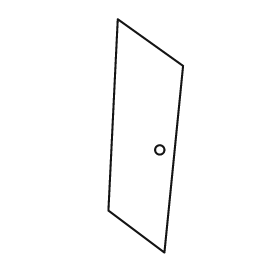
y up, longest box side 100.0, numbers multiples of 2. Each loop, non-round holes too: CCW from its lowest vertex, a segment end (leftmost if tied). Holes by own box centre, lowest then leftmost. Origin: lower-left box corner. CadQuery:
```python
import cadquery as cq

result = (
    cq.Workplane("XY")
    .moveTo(24.0, 0.0)
    .lineTo(32.0, 80.0)
    .lineTo(4.0, 100.0)
    .lineTo(0.0, 18.0)
    .close()
    .moveTo(22.0, 44.0)
    .circle(2.0)
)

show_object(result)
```